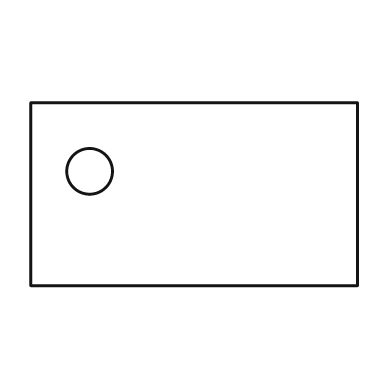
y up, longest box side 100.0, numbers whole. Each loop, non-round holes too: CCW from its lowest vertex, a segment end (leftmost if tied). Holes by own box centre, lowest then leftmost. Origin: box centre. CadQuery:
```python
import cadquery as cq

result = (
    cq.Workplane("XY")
    .moveTo(-50.0, -28.0)
    .lineTo(50.0, -28.0)
    .lineTo(50.0, 28.0)
    .lineTo(-50.0, 28.0)
    .close()
    .moveTo(-32.0, 7.0)
    .circle(7.0)
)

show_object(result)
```